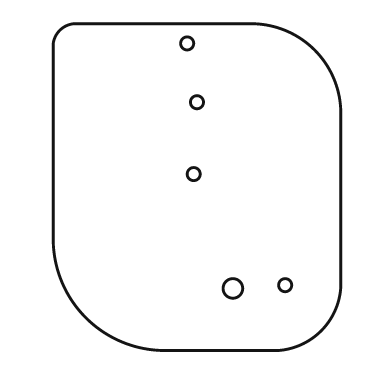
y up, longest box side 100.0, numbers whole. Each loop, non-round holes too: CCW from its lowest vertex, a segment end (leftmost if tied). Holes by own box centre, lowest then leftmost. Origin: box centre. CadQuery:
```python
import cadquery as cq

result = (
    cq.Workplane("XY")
    .moveTo(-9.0, -50.0)
    .lineTo(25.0, -50.0)
    .threePointArc((38.0, -44.0), (44.0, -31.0))
    .lineTo(44.0, 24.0)
    .threePointArc((36.0, 42.0), (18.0, 50.0))
    .lineTo(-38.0, 50.0)
    .threePointArc((-42.0, 48.0), (-44.0, 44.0))
    .lineTo(-44.0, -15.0)
    .threePointArc((-34.0, -40.0), (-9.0, -50.0))
    .close()
    .moveTo(11.0, -31.0)
    .circle(3.0)
    .moveTo(27.0, -30.0)
    .circle(2.0)
    .moveTo(-1.0, 4.0)
    .circle(2.0)
    .moveTo(0.0, 26.0)
    .circle(2.0)
    .moveTo(-3.0, 44.0)
    .circle(2.0)
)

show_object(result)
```